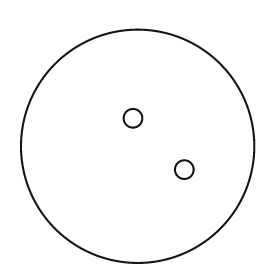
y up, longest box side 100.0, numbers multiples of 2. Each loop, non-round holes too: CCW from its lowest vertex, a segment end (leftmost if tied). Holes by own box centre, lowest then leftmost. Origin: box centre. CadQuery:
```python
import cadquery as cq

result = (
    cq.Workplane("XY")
    .moveTo(0.0, 0.0)
    .circle(50.0)
    .moveTo(20.0, -10.0)
    .circle(4.0)
    .moveTo(-2.0, 12.0)
    .circle(4.0)
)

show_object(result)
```